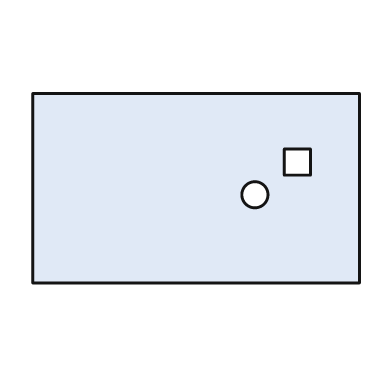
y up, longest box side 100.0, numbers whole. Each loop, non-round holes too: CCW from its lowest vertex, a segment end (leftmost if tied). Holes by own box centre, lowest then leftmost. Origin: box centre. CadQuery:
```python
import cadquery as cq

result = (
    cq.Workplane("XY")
    .moveTo(-50.0, -29.0)
    .lineTo(50.0, -29.0)
    .lineTo(50.0, 29.0)
    .lineTo(-50.0, 29.0)
    .close()
    .moveTo(18.0, -2.0)
    .circle(4.0)
    .moveTo(27.0, 4.0)
    .lineTo(35.0, 4.0)
    .lineTo(35.0, 12.0)
    .lineTo(27.0, 12.0)
    .close()
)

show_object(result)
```